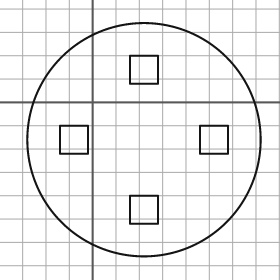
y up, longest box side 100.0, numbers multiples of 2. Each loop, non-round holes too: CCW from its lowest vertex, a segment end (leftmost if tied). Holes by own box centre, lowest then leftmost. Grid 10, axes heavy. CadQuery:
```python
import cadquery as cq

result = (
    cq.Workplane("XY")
    .moveTo(22.0, -16.0)
    .circle(50.0)
    .moveTo(16.0, -52.0)
    .lineTo(28.0, -52.0)
    .lineTo(28.0, -40.0)
    .lineTo(16.0, -40.0)
    .close()
    .moveTo(-14.0, -22.0)
    .lineTo(-2.0, -22.0)
    .lineTo(-2.0, -10.0)
    .lineTo(-14.0, -10.0)
    .close()
    .moveTo(46.0, -22.0)
    .lineTo(58.0, -22.0)
    .lineTo(58.0, -10.0)
    .lineTo(46.0, -10.0)
    .close()
    .moveTo(16.0, 8.0)
    .lineTo(28.0, 8.0)
    .lineTo(28.0, 20.0)
    .lineTo(16.0, 20.0)
    .close()
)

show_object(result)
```